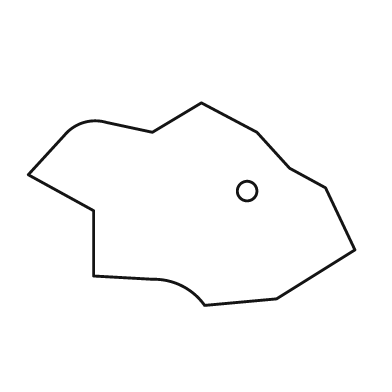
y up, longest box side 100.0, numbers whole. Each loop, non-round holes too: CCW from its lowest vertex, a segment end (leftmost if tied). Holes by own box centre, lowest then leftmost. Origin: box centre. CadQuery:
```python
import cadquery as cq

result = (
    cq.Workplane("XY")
    .moveTo(4.0, -31.0)
    .lineTo(26.0, -29.0)
    .lineTo(50.0, -14.0)
    .lineTo(41.0, 5.0)
    .lineTo(30.0, 11.0)
    .lineTo(20.0, 22.0)
    .lineTo(3.0, 31.0)
    .lineTo(-12.0, 22.0)
    .lineTo(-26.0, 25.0)
    .threePointArc((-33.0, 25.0), (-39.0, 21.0))
    .lineTo(-50.0, 9.0)
    .lineTo(-30.0, -2.0)
    .lineTo(-30.0, -22.0)
    .lineTo(-12.0, -23.0)
    .threePointArc((-3.0, -25.0), (4.0, -31.0))
    .close()
    .moveTo(17.0, 4.0)
    .circle(3.0)
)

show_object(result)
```